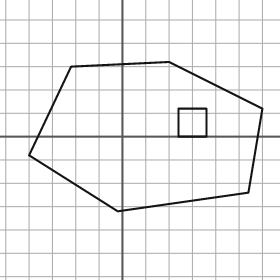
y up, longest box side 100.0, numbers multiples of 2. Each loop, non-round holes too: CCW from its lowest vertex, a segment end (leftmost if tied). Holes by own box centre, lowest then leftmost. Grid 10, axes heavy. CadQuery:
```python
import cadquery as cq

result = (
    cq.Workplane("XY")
    .moveTo(-2.0, -32.0)
    .lineTo(54.0, -24.0)
    .lineTo(60.0, 12.0)
    .lineTo(20.0, 32.0)
    .lineTo(-22.0, 30.0)
    .lineTo(-40.0, -8.0)
    .close()
    .moveTo(24.0, 0.0)
    .lineTo(36.0, 0.0)
    .lineTo(36.0, 12.0)
    .lineTo(24.0, 12.0)
    .close()
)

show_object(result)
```